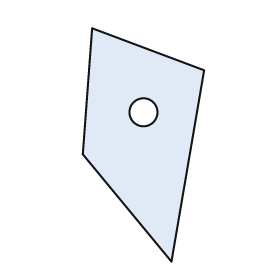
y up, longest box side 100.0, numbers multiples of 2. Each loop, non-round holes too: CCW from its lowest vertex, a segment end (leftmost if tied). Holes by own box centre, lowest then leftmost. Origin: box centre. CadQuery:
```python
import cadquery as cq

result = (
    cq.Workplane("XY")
    .moveTo(12.0, -50.0)
    .lineTo(26.0, 32.0)
    .lineTo(-22.0, 50.0)
    .lineTo(-26.0, -4.0)
    .close()
    .moveTo(0.0, 14.0)
    .circle(6.0)
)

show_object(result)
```